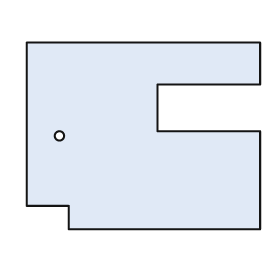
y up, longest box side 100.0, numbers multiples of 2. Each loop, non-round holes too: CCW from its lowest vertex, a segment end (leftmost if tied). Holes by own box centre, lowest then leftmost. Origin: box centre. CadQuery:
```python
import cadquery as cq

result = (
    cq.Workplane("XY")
    .moveTo(-32.0, -40.0)
    .lineTo(50.0, -40.0)
    .lineTo(50.0, 2.0)
    .lineTo(6.0, 2.0)
    .lineTo(6.0, 22.0)
    .lineTo(50.0, 22.0)
    .lineTo(50.0, 40.0)
    .lineTo(-50.0, 40.0)
    .lineTo(-50.0, -30.0)
    .lineTo(-32.0, -30.0)
    .close()
    .moveTo(-36.0, 0.0)
    .circle(2.0)
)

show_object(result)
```